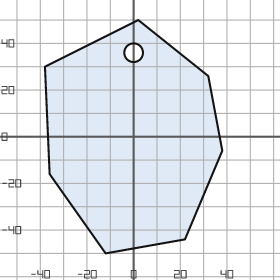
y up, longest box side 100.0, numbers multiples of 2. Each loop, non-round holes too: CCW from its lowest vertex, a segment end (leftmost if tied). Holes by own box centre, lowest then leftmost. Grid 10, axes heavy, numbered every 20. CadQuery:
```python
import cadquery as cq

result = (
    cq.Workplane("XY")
    .moveTo(-12.0, -50.0)
    .lineTo(22.0, -44.0)
    .lineTo(38.0, -6.0)
    .lineTo(32.0, 26.0)
    .lineTo(2.0, 50.0)
    .lineTo(-38.0, 30.0)
    .lineTo(-36.0, -16.0)
    .close()
    .moveTo(0.0, 36.0)
    .circle(4.0)
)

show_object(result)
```